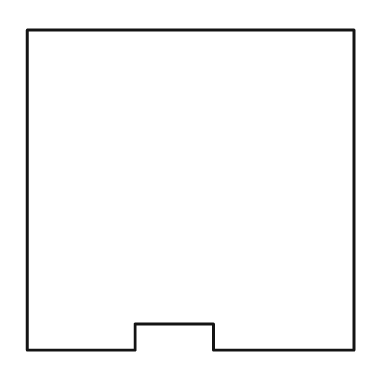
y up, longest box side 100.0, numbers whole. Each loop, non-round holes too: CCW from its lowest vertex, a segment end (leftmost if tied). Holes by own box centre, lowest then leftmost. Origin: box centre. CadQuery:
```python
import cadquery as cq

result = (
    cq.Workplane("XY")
    .moveTo(-50.0, -49.0)
    .lineTo(-17.0, -49.0)
    .lineTo(-17.0, -41.0)
    .lineTo(7.0, -41.0)
    .lineTo(7.0, -49.0)
    .lineTo(50.0, -49.0)
    .lineTo(50.0, 49.0)
    .lineTo(-50.0, 49.0)
    .close()
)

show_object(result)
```